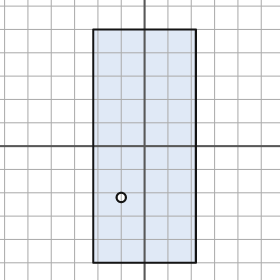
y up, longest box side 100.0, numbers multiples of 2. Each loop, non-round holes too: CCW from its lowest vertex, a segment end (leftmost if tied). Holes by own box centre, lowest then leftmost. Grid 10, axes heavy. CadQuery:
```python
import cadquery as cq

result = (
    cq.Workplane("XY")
    .moveTo(-22.0, -50.0)
    .lineTo(22.0, -50.0)
    .lineTo(22.0, 50.0)
    .lineTo(-22.0, 50.0)
    .close()
    .moveTo(-10.0, -22.0)
    .circle(2.0)
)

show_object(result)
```